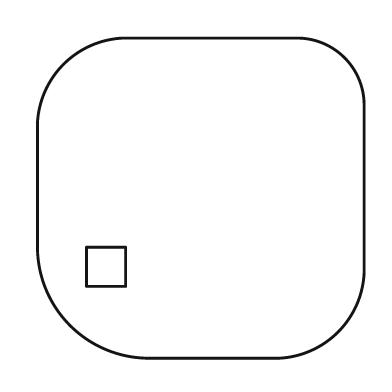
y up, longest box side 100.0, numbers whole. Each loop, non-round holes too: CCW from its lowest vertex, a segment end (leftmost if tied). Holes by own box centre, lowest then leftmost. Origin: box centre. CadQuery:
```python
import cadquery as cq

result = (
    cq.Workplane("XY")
    .moveTo(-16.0, -49.0)
    .lineTo(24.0, -49.0)
    .threePointArc((42.0, -41.0), (50.0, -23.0))
    .lineTo(50.0, 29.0)
    .threePointArc((44.0, 43.0), (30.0, 49.0))
    .lineTo(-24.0, 49.0)
    .threePointArc((-42.0, 41.0), (-50.0, 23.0))
    .lineTo(-50.0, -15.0)
    .threePointArc((-40.0, -39.0), (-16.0, -49.0))
    .close()
    .moveTo(-35.0, -27.0)
    .lineTo(-23.0, -27.0)
    .lineTo(-23.0, -15.0)
    .lineTo(-35.0, -15.0)
    .close()
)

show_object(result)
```